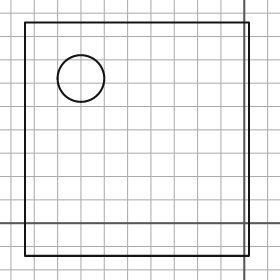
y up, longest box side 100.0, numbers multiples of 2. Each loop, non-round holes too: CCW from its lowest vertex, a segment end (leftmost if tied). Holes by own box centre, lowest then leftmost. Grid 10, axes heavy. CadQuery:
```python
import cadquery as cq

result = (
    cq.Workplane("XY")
    .moveTo(-94.0, -14.0)
    .lineTo(2.0, -14.0)
    .lineTo(2.0, 86.0)
    .lineTo(-94.0, 86.0)
    .close()
    .moveTo(-70.0, 62.0)
    .circle(10.0)
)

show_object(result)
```